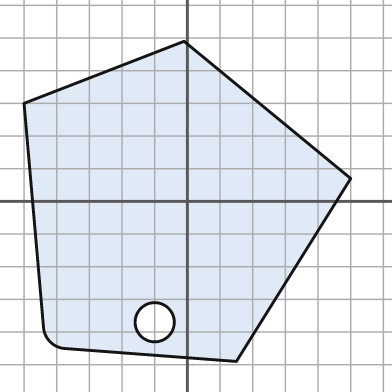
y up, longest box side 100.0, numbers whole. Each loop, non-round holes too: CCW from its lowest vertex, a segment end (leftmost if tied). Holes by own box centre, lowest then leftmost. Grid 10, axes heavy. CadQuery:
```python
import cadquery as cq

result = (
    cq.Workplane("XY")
    .moveTo(15.0, -49.0)
    .lineTo(50.0, 7.0)
    .lineTo(-1.0, 49.0)
    .lineTo(-50.0, 30.0)
    .lineTo(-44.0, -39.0)
    .threePointArc((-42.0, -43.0), (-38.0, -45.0))
    .close()
    .moveTo(-10.0, -37.0)
    .circle(6.0)
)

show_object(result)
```